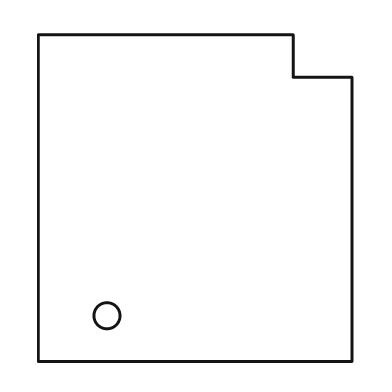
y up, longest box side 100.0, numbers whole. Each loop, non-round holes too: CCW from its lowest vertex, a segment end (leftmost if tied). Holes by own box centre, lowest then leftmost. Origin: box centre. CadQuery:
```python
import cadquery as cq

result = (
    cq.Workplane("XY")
    .moveTo(-48.0, -50.0)
    .lineTo(48.0, -50.0)
    .lineTo(48.0, 37.0)
    .lineTo(30.0, 37.0)
    .lineTo(30.0, 50.0)
    .lineTo(-48.0, 50.0)
    .close()
    .moveTo(-27.0, -36.0)
    .circle(4.0)
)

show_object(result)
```